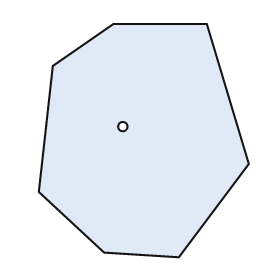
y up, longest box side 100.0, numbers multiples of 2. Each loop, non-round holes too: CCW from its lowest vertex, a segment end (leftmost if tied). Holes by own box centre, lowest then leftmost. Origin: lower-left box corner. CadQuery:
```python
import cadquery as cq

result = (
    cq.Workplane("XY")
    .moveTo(60.0, 0.0)
    .lineTo(90.0, 40.0)
    .lineTo(72.0, 100.0)
    .lineTo(32.0, 100.0)
    .lineTo(6.0, 82.0)
    .lineTo(0.0, 28.0)
    .lineTo(28.0, 2.0)
    .close()
    .moveTo(36.0, 56.0)
    .circle(2.0)
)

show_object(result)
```